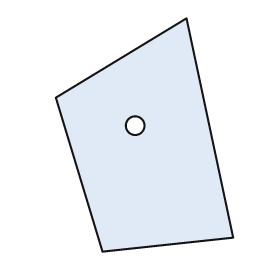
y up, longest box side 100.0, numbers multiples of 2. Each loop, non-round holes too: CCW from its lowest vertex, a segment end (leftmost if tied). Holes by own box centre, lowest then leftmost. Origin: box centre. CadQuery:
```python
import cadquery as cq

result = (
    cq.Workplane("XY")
    .moveTo(-18.0, -50.0)
    .lineTo(38.0, -44.0)
    .lineTo(18.0, 50.0)
    .lineTo(-38.0, 16.0)
    .close()
    .moveTo(-4.0, 4.0)
    .circle(4.0)
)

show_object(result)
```